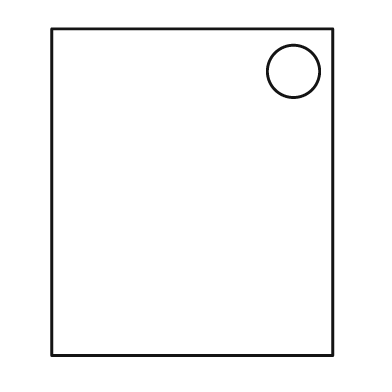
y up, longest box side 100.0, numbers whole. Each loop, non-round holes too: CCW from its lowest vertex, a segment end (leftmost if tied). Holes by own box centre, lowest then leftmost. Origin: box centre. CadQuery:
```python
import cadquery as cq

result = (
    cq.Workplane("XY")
    .moveTo(-43.0, -50.0)
    .lineTo(43.0, -50.0)
    .lineTo(43.0, 50.0)
    .lineTo(-43.0, 50.0)
    .close()
    .moveTo(31.0, 37.0)
    .circle(8.0)
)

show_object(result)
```